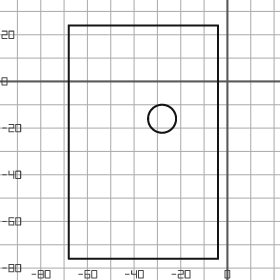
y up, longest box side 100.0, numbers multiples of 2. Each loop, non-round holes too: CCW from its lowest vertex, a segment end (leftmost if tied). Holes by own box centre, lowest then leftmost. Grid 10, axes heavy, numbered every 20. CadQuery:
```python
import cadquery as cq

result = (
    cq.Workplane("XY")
    .moveTo(-68.0, -76.0)
    .lineTo(-4.0, -76.0)
    .lineTo(-4.0, 24.0)
    .lineTo(-68.0, 24.0)
    .close()
    .moveTo(-28.0, -16.0)
    .circle(6.0)
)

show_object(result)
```